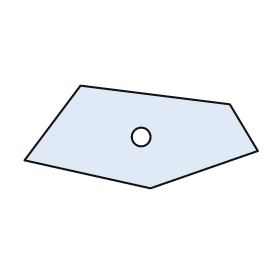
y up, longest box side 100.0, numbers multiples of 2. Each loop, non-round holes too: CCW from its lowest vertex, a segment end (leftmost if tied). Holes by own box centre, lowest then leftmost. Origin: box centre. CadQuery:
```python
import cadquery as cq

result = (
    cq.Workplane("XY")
    .moveTo(4.0, -22.0)
    .lineTo(50.0, -6.0)
    .lineTo(38.0, 14.0)
    .lineTo(-26.0, 22.0)
    .lineTo(-50.0, -10.0)
    .close()
    .moveTo(0.0, 0.0)
    .circle(4.0)
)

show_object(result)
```